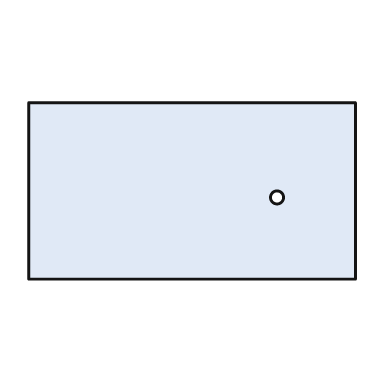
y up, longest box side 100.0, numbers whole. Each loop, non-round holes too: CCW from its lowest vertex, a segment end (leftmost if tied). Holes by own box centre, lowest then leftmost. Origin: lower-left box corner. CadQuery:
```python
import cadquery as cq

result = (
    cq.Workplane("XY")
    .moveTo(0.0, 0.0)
    .lineTo(100.0, 0.0)
    .lineTo(100.0, 54.0)
    .lineTo(0.0, 54.0)
    .close()
    .moveTo(76.0, 25.0)
    .circle(2.0)
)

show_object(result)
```